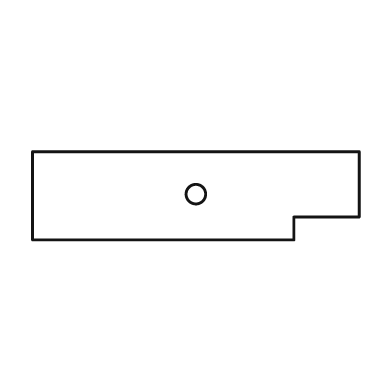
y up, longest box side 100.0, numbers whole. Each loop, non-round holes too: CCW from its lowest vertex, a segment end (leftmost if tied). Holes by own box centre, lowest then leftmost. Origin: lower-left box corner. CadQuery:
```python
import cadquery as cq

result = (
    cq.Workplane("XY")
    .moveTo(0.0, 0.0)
    .lineTo(80.0, 0.0)
    .lineTo(80.0, 7.0)
    .lineTo(100.0, 7.0)
    .lineTo(100.0, 27.0)
    .lineTo(0.0, 27.0)
    .close()
    .moveTo(50.0, 14.0)
    .circle(3.0)
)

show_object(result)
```